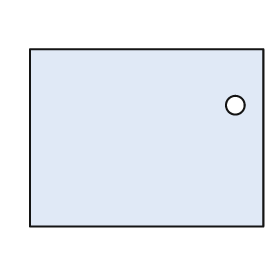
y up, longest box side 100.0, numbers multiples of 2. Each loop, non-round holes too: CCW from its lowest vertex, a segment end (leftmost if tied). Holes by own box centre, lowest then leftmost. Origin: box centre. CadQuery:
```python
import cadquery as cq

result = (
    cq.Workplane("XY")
    .moveTo(-50.0, -38.0)
    .lineTo(50.0, -38.0)
    .lineTo(50.0, 38.0)
    .lineTo(-50.0, 38.0)
    .close()
    .moveTo(38.0, 14.0)
    .circle(4.0)
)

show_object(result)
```